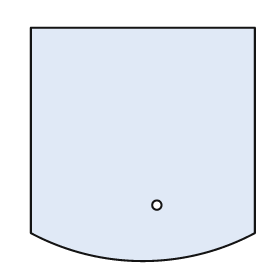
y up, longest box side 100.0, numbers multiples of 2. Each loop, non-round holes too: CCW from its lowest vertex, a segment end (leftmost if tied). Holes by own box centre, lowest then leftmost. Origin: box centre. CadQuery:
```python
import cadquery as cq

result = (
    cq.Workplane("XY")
    .moveTo(-48.0, -38.0)
    .threePointArc((0.0, -50.0), (48.0, -38.0))
    .lineTo(48.0, 50.0)
    .lineTo(-48.0, 50.0)
    .close()
    .moveTo(6.0, -26.0)
    .circle(2.0)
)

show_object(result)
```